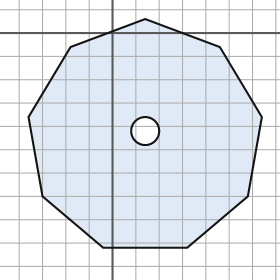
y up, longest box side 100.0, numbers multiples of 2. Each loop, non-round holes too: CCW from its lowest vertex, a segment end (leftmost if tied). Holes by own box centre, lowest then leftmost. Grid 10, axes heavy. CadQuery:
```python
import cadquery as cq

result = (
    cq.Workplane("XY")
    .moveTo(-4.0, -92.0)
    .lineTo(32.0, -92.0)
    .lineTo(58.0, -70.0)
    .lineTo(64.0, -36.0)
    .lineTo(46.0, -6.0)
    .lineTo(14.0, 6.0)
    .lineTo(-18.0, -6.0)
    .lineTo(-36.0, -36.0)
    .lineTo(-30.0, -70.0)
    .close()
    .moveTo(14.0, -42.0)
    .circle(6.0)
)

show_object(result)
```